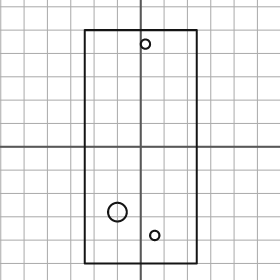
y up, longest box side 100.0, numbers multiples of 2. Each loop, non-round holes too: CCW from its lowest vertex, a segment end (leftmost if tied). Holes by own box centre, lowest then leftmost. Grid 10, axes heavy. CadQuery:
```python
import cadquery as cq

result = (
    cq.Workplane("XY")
    .moveTo(-24.0, -50.0)
    .lineTo(24.0, -50.0)
    .lineTo(24.0, 50.0)
    .lineTo(-24.0, 50.0)
    .close()
    .moveTo(6.0, -38.0)
    .circle(2.0)
    .moveTo(-10.0, -28.0)
    .circle(4.0)
    .moveTo(2.0, 44.0)
    .circle(2.0)
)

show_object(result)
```